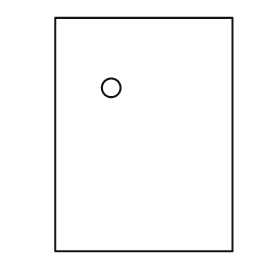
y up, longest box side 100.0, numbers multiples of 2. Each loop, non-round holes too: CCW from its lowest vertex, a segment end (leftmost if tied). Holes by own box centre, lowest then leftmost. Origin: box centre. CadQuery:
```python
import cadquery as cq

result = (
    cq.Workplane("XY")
    .moveTo(-38.0, -50.0)
    .lineTo(38.0, -50.0)
    .lineTo(38.0, 50.0)
    .lineTo(-38.0, 50.0)
    .close()
    .moveTo(-14.0, 20.0)
    .circle(4.0)
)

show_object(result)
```